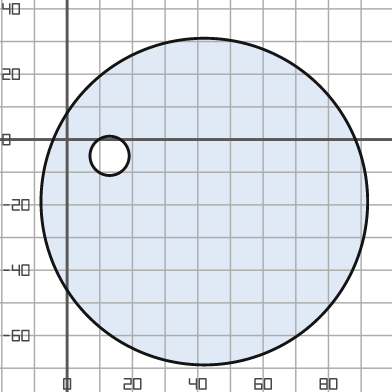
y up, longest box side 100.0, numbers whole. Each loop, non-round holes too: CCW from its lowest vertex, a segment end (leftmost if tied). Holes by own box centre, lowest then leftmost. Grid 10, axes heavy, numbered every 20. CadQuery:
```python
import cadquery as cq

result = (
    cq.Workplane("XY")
    .moveTo(42.0, -19.0)
    .circle(50.0)
    .moveTo(13.0, -5.0)
    .circle(6.0)
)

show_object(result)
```